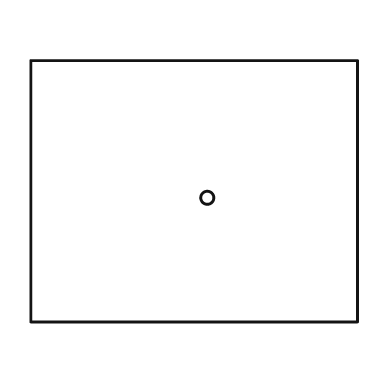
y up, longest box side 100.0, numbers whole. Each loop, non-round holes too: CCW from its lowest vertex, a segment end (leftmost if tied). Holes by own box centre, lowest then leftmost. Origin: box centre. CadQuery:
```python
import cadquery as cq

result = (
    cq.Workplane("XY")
    .moveTo(-50.0, -40.0)
    .lineTo(50.0, -40.0)
    .lineTo(50.0, 40.0)
    .lineTo(-50.0, 40.0)
    .close()
    .moveTo(4.0, -2.0)
    .circle(2.0)
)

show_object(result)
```